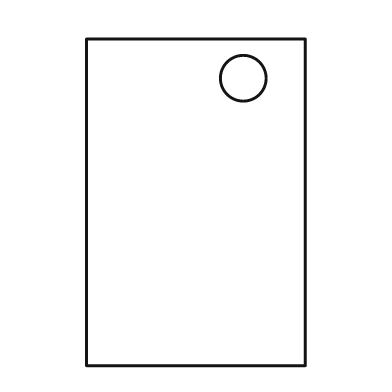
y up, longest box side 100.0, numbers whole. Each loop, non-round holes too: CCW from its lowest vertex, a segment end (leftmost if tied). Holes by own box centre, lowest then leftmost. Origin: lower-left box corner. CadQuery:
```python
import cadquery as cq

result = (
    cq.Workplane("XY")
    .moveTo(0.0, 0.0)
    .lineTo(67.0, 0.0)
    .lineTo(67.0, 100.0)
    .lineTo(0.0, 100.0)
    .close()
    .moveTo(48.0, 88.0)
    .circle(7.0)
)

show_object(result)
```